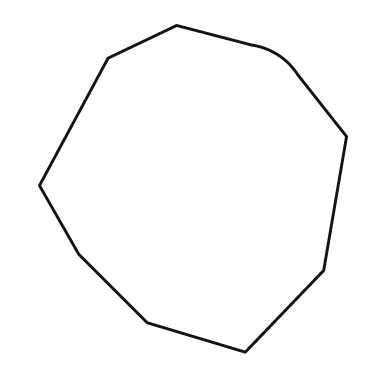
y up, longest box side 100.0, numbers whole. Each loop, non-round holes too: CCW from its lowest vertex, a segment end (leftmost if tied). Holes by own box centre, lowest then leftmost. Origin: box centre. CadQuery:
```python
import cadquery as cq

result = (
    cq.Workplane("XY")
    .moveTo(16.0, -50.0)
    .lineTo(40.0, -25.0)
    .lineTo(47.0, 16.0)
    .lineTo(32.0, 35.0)
    .threePointArc((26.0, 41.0), (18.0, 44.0))
    .lineTo(-5.0, 50.0)
    .lineTo(-26.0, 40.0)
    .lineTo(-47.0, 1.0)
    .lineTo(-35.0, -20.0)
    .lineTo(-14.0, -41.0)
    .close()
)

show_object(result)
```